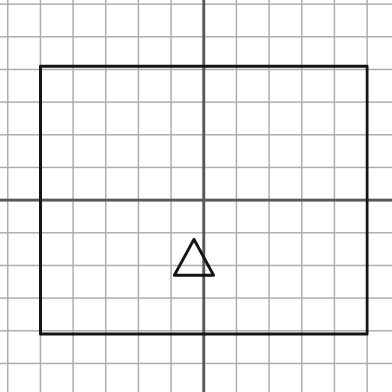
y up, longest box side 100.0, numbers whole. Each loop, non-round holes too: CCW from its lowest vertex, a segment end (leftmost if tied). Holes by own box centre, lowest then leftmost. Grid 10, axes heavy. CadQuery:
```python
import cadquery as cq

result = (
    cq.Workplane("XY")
    .moveTo(-50.0, -41.0)
    .lineTo(50.0, -41.0)
    .lineTo(50.0, 41.0)
    .lineTo(-50.0, 41.0)
    .close()
    .moveTo(-9.0, -23.0)
    .lineTo(3.0, -23.0)
    .lineTo(-3.0, -12.0)
    .close()
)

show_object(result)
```